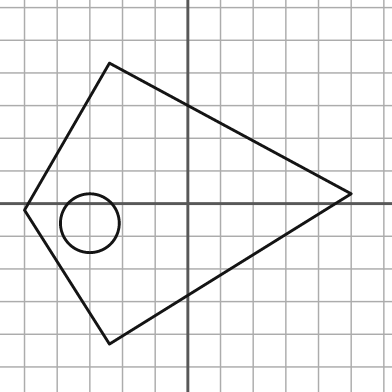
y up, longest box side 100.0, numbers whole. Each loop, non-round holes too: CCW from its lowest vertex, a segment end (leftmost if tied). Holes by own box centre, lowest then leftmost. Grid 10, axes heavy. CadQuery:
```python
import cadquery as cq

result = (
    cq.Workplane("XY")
    .moveTo(-24.0, -43.0)
    .lineTo(50.0, 3.0)
    .lineTo(-24.0, 43.0)
    .lineTo(-50.0, -2.0)
    .close()
    .moveTo(-30.0, -6.0)
    .circle(9.0)
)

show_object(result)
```